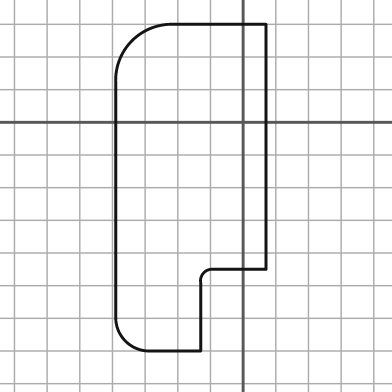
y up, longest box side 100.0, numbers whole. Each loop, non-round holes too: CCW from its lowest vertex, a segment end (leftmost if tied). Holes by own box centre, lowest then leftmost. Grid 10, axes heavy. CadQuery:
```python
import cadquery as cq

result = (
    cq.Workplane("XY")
    .moveTo(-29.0, -70.0)
    .lineTo(-13.0, -70.0)
    .lineTo(-13.0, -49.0)
    .threePointArc((-12.0, -46.0), (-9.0, -45.0))
    .lineTo(7.0, -45.0)
    .lineTo(7.0, 30.0)
    .lineTo(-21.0, 30.0)
    .threePointArc((-34.0, 25.0), (-39.0, 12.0))
    .lineTo(-39.0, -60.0)
    .threePointArc((-36.0, -67.0), (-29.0, -70.0))
    .close()
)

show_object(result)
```